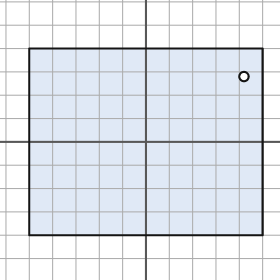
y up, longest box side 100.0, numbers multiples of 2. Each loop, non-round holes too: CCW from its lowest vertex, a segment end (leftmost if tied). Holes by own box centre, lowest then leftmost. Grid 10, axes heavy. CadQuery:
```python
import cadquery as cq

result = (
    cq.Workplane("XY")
    .moveTo(-50.0, -40.0)
    .lineTo(50.0, -40.0)
    .lineTo(50.0, 40.0)
    .lineTo(-50.0, 40.0)
    .close()
    .moveTo(42.0, 28.0)
    .circle(2.0)
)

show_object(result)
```